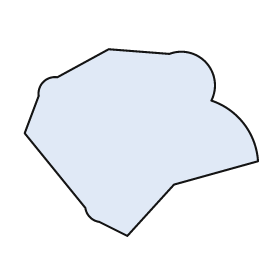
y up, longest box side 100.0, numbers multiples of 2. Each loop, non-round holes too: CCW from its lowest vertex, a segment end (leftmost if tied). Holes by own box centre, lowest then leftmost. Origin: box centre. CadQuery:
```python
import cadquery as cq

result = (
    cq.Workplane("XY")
    .moveTo(-6.0, -40.0)
    .lineTo(14.0, -18.0)
    .lineTo(50.0, -8.0)
    .threePointArc((44.0, 8.0), (30.0, 18.0))
    .threePointArc((28.0, 34.0), (12.0, 38.0))
    .lineTo(-14.0, 40.0)
    .lineTo(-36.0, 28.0)
    .threePointArc((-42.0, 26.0), (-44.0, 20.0))
    .lineTo(-50.0, 4.0)
    .lineTo(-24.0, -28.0)
    .threePointArc((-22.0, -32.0), (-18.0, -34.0))
    .close()
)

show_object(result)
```